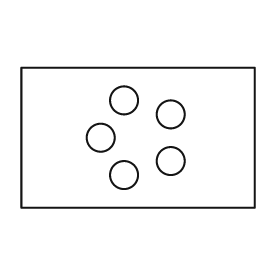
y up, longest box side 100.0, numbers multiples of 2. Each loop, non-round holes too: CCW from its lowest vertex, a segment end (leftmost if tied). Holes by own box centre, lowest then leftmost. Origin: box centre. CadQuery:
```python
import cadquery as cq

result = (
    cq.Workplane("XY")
    .moveTo(-50.0, -30.0)
    .lineTo(50.0, -30.0)
    .lineTo(50.0, 30.0)
    .lineTo(-50.0, 30.0)
    .close()
    .moveTo(-6.0, -16.0)
    .circle(6.0)
    .moveTo(14.0, -10.0)
    .circle(6.0)
    .moveTo(-16.0, 0.0)
    .circle(6.0)
    .moveTo(14.0, 10.0)
    .circle(6.0)
    .moveTo(-6.0, 16.0)
    .circle(6.0)
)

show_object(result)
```